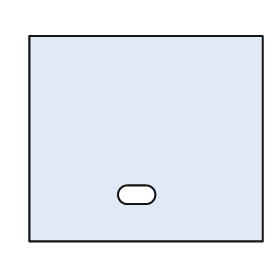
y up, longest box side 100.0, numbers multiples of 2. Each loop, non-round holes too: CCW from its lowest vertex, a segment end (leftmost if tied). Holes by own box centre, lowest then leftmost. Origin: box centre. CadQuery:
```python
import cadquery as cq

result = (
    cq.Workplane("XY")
    .moveTo(-50.0, -44.0)
    .lineTo(50.0, -44.0)
    .lineTo(50.0, 44.0)
    .lineTo(-50.0, 44.0)
    .close()
    .moveTo(-8.0, -28.0)
    .lineTo(0.0, -28.0)
    .threePointArc((4.0, -24.0), (0.0, -20.0))
    .lineTo(-8.0, -20.0)
    .threePointArc((-12.0, -24.0), (-8.0, -28.0))
    .close()
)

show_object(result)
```